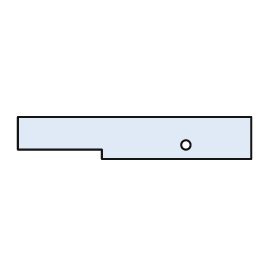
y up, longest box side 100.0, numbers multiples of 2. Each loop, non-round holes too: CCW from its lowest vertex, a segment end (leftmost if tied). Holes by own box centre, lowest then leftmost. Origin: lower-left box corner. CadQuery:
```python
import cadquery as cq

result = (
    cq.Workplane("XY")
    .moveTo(36.0, 0.0)
    .lineTo(100.0, 0.0)
    .lineTo(100.0, 18.0)
    .lineTo(0.0, 18.0)
    .lineTo(0.0, 4.0)
    .lineTo(36.0, 4.0)
    .close()
    .moveTo(72.0, 6.0)
    .circle(2.0)
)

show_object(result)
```